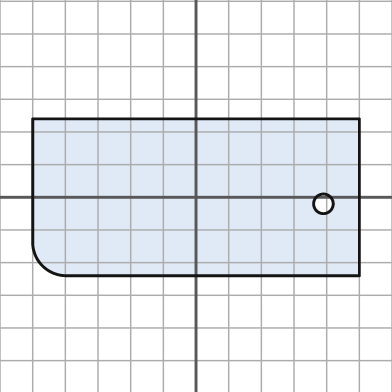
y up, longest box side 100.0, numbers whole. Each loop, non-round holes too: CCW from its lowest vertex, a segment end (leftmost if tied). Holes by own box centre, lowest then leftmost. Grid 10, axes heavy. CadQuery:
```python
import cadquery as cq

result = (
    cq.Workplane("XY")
    .moveTo(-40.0, -24.0)
    .lineTo(50.0, -24.0)
    .lineTo(50.0, 24.0)
    .lineTo(-50.0, 24.0)
    .lineTo(-50.0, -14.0)
    .threePointArc((-47.0, -21.0), (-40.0, -24.0))
    .close()
    .moveTo(39.0, -2.0)
    .circle(3.0)
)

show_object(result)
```